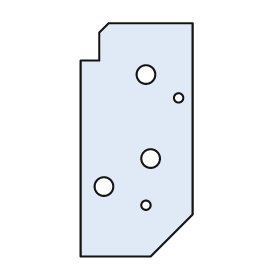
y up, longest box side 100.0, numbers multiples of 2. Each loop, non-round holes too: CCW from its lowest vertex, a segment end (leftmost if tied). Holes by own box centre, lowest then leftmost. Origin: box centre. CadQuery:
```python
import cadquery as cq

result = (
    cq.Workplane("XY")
    .moveTo(-24.0, -50.0)
    .lineTo(6.0, -50.0)
    .lineTo(24.0, -32.0)
    .lineTo(24.0, 50.0)
    .lineTo(-12.0, 50.0)
    .lineTo(-16.0, 46.0)
    .lineTo(-16.0, 34.0)
    .lineTo(-24.0, 34.0)
    .close()
    .moveTo(4.0, -28.0)
    .circle(2.0)
    .moveTo(-14.0, -20.0)
    .circle(4.0)
    .moveTo(6.0, -8.0)
    .circle(4.0)
    .moveTo(18.0, 18.0)
    .circle(2.0)
    .moveTo(4.0, 28.0)
    .circle(4.0)
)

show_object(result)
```